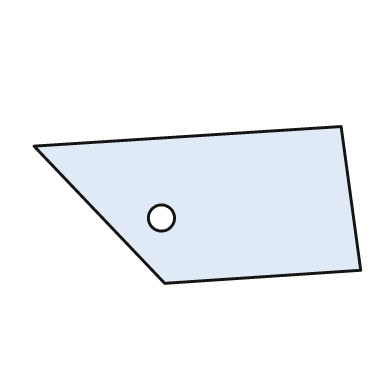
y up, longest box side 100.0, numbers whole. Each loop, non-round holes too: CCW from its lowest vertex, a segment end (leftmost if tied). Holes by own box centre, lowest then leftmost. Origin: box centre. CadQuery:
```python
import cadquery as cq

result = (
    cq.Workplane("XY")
    .moveTo(-10.0, -24.0)
    .lineTo(50.0, -20.0)
    .lineTo(44.0, 24.0)
    .lineTo(-50.0, 18.0)
    .close()
    .moveTo(-11.0, -4.0)
    .circle(4.0)
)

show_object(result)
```